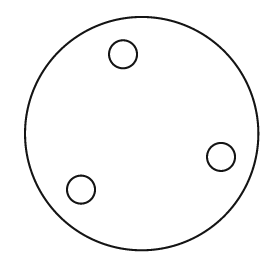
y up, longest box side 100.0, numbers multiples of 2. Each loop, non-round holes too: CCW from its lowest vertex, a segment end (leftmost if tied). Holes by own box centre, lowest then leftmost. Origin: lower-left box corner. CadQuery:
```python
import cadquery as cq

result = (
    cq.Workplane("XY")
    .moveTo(50.0, 50.0)
    .circle(50.0)
    .moveTo(24.0, 26.0)
    .circle(6.0)
    .moveTo(84.0, 40.0)
    .circle(6.0)
    .moveTo(42.0, 84.0)
    .circle(6.0)
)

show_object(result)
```